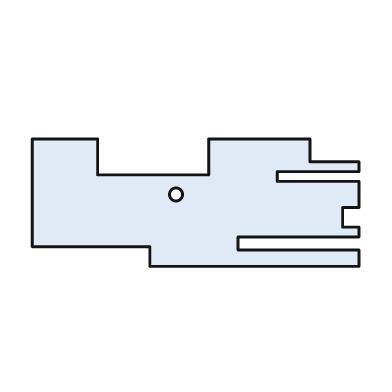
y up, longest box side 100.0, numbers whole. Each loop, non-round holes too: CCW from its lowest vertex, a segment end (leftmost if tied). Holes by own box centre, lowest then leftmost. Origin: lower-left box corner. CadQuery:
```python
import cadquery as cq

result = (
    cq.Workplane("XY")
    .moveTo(36.0, 0.0)
    .lineTo(100.0, 0.0)
    .lineTo(100.0, 5.0)
    .lineTo(63.0, 5.0)
    .lineTo(63.0, 9.0)
    .lineTo(100.0, 9.0)
    .lineTo(100.0, 12.0)
    .lineTo(95.0, 12.0)
    .lineTo(95.0, 18.0)
    .lineTo(100.0, 18.0)
    .lineTo(100.0, 26.0)
    .lineTo(75.0, 26.0)
    .lineTo(75.0, 29.0)
    .lineTo(100.0, 29.0)
    .lineTo(100.0, 32.0)
    .lineTo(85.0, 32.0)
    .lineTo(85.0, 39.0)
    .lineTo(54.0, 39.0)
    .lineTo(54.0, 28.0)
    .lineTo(20.0, 28.0)
    .lineTo(20.0, 39.0)
    .lineTo(0.0, 39.0)
    .lineTo(0.0, 6.0)
    .lineTo(36.0, 6.0)
    .close()
    .moveTo(44.0, 22.0)
    .circle(2.0)
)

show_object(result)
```